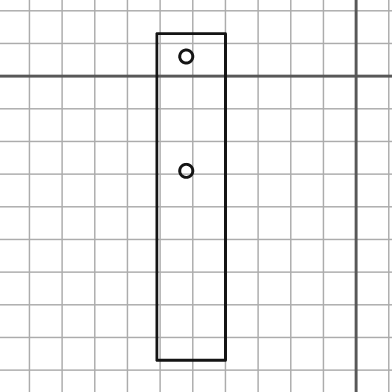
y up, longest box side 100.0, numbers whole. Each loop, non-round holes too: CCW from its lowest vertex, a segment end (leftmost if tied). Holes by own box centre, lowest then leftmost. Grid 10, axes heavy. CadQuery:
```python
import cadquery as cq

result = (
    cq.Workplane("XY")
    .moveTo(-61.0, -87.0)
    .lineTo(-40.0, -87.0)
    .lineTo(-40.0, 13.0)
    .lineTo(-61.0, 13.0)
    .close()
    .moveTo(-52.0, -29.0)
    .circle(2.0)
    .moveTo(-52.0, 6.0)
    .circle(2.0)
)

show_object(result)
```